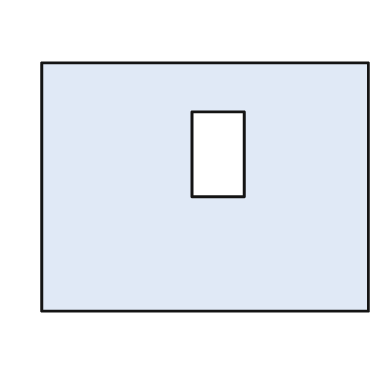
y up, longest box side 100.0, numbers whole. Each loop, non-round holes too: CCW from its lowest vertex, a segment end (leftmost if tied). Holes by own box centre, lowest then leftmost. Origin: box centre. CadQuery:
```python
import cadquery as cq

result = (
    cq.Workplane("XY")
    .moveTo(-50.0, -38.0)
    .lineTo(50.0, -38.0)
    .lineTo(50.0, 38.0)
    .lineTo(-50.0, 38.0)
    .close()
    .moveTo(-4.0, -3.0)
    .lineTo(12.0, -3.0)
    .lineTo(12.0, 23.0)
    .lineTo(-4.0, 23.0)
    .close()
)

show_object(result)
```